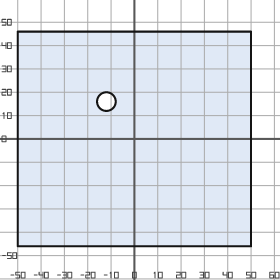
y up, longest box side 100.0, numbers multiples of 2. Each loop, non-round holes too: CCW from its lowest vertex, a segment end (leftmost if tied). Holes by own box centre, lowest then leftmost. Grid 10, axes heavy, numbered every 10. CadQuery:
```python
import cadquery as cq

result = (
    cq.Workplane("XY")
    .moveTo(-50.0, -46.0)
    .lineTo(50.0, -46.0)
    .lineTo(50.0, 46.0)
    .lineTo(-50.0, 46.0)
    .close()
    .moveTo(-12.0, 16.0)
    .circle(4.0)
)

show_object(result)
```